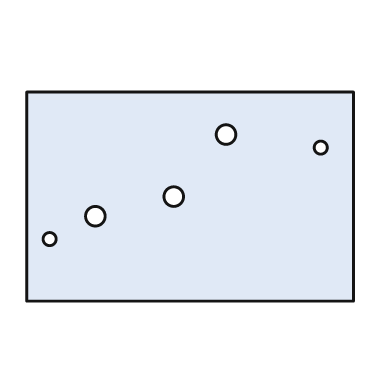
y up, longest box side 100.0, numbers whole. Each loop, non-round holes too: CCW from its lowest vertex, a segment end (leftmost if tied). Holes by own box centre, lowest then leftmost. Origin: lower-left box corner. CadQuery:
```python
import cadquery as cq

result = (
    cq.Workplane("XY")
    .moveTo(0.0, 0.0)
    .lineTo(100.0, 0.0)
    .lineTo(100.0, 64.0)
    .lineTo(0.0, 64.0)
    .close()
    .moveTo(7.0, 19.0)
    .circle(2.0)
    .moveTo(21.0, 26.0)
    .circle(3.0)
    .moveTo(45.0, 32.0)
    .circle(3.0)
    .moveTo(90.0, 47.0)
    .circle(2.0)
    .moveTo(61.0, 51.0)
    .circle(3.0)
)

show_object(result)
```